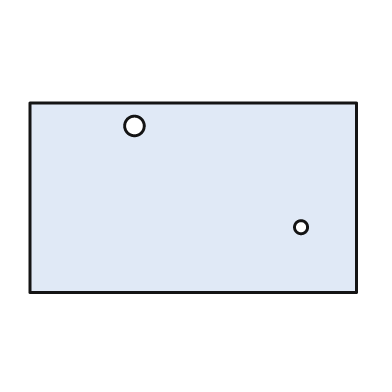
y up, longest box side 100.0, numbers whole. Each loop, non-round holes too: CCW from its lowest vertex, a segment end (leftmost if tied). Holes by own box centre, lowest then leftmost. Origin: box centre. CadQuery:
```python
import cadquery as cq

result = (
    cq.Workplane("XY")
    .moveTo(-50.0, -29.0)
    .lineTo(50.0, -29.0)
    .lineTo(50.0, 29.0)
    .lineTo(-50.0, 29.0)
    .close()
    .moveTo(33.0, -9.0)
    .circle(2.0)
    .moveTo(-18.0, 22.0)
    .circle(3.0)
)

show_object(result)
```